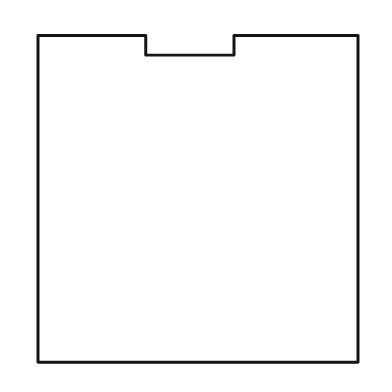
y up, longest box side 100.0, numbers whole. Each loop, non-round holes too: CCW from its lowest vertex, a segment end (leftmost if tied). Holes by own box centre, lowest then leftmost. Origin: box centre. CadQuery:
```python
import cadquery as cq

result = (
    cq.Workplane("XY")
    .moveTo(-49.0, -50.0)
    .lineTo(49.0, -50.0)
    .lineTo(49.0, 50.0)
    .lineTo(11.0, 50.0)
    .lineTo(11.0, 44.0)
    .lineTo(-16.0, 44.0)
    .lineTo(-16.0, 50.0)
    .lineTo(-49.0, 50.0)
    .close()
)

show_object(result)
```